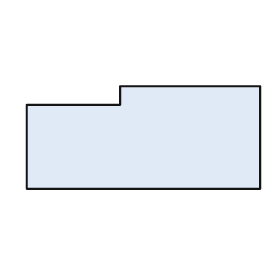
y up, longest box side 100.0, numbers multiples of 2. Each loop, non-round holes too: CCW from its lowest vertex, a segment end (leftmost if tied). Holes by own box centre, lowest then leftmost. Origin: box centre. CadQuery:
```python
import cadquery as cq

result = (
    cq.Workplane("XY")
    .moveTo(-50.0, -22.0)
    .lineTo(50.0, -22.0)
    .lineTo(50.0, 22.0)
    .lineTo(-10.0, 22.0)
    .lineTo(-10.0, 14.0)
    .lineTo(-50.0, 14.0)
    .close()
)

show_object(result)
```